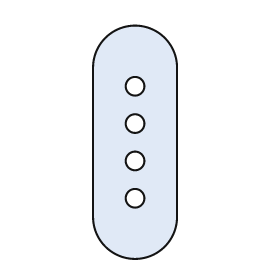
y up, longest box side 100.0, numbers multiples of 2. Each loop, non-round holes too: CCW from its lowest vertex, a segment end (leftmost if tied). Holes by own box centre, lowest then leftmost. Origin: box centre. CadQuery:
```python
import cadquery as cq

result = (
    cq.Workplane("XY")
    .moveTo(-18.0, -32.0)
    .threePointArc((0.0, -50.0), (18.0, -32.0))
    .lineTo(18.0, 32.0)
    .threePointArc((0.0, 50.0), (-18.0, 32.0))
    .close()
    .moveTo(0.0, -24.0)
    .circle(4.0)
    .moveTo(0.0, -8.0)
    .circle(4.0)
    .moveTo(0.0, 8.0)
    .circle(4.0)
    .moveTo(0.0, 24.0)
    .circle(4.0)
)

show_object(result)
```